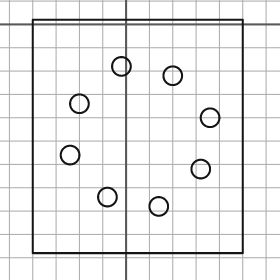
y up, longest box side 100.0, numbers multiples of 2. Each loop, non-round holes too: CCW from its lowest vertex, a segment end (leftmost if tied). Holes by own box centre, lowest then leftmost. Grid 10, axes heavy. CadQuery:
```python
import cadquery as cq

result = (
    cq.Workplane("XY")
    .moveTo(-40.0, -98.0)
    .lineTo(50.0, -98.0)
    .lineTo(50.0, 2.0)
    .lineTo(-40.0, 2.0)
    .close()
    .moveTo(14.0, -78.0)
    .circle(4.0)
    .moveTo(-8.0, -74.0)
    .circle(4.0)
    .moveTo(32.0, -62.0)
    .circle(4.0)
    .moveTo(-24.0, -56.0)
    .circle(4.0)
    .moveTo(36.0, -40.0)
    .circle(4.0)
    .moveTo(-20.0, -34.0)
    .circle(4.0)
    .moveTo(20.0, -22.0)
    .circle(4.0)
    .moveTo(-2.0, -18.0)
    .circle(4.0)
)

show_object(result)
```